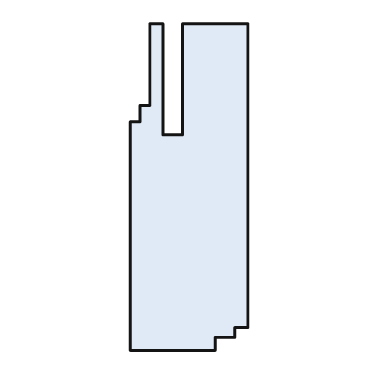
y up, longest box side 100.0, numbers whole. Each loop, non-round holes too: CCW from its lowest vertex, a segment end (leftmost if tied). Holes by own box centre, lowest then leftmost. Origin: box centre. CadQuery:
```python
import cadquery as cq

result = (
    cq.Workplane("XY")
    .moveTo(-18.0, -50.0)
    .lineTo(8.0, -50.0)
    .lineTo(8.0, -46.0)
    .lineTo(14.0, -46.0)
    .lineTo(14.0, -43.0)
    .lineTo(18.0, -43.0)
    .lineTo(18.0, 50.0)
    .lineTo(-2.0, 50.0)
    .lineTo(-2.0, 16.0)
    .lineTo(-8.0, 16.0)
    .lineTo(-8.0, 50.0)
    .lineTo(-12.0, 50.0)
    .lineTo(-12.0, 25.0)
    .lineTo(-15.0, 25.0)
    .lineTo(-15.0, 20.0)
    .lineTo(-18.0, 20.0)
    .close()
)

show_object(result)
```